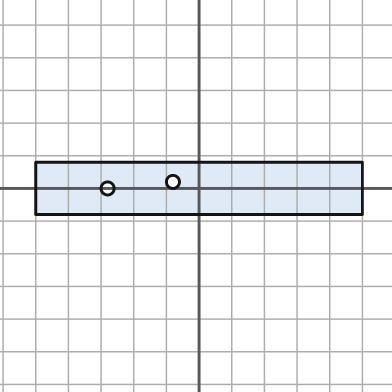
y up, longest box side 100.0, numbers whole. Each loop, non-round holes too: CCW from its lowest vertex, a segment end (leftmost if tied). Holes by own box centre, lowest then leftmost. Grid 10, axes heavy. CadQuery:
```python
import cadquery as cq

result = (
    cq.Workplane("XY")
    .moveTo(-50.0, -8.0)
    .lineTo(50.0, -8.0)
    .lineTo(50.0, 8.0)
    .lineTo(-50.0, 8.0)
    .close()
    .moveTo(-28.0, 0.0)
    .circle(2.0)
    .moveTo(-8.0, 2.0)
    .circle(2.0)
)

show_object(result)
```